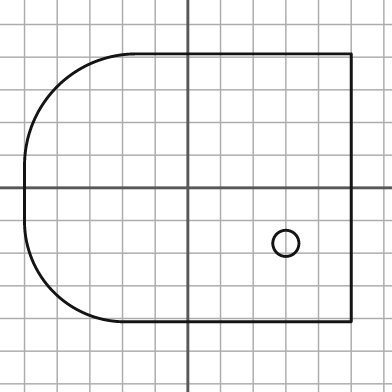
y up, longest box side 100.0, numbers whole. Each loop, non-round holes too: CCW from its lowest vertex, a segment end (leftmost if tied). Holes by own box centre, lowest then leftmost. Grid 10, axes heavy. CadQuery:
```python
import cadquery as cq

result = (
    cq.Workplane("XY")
    .moveTo(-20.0, -41.0)
    .lineTo(50.0, -41.0)
    .lineTo(50.0, 41.0)
    .lineTo(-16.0, 41.0)
    .threePointArc((-40.0, 31.0), (-50.0, 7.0))
    .lineTo(-50.0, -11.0)
    .threePointArc((-41.0, -32.0), (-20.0, -41.0))
    .close()
    .moveTo(30.0, -17.0)
    .circle(4.0)
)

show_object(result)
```